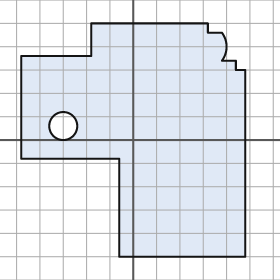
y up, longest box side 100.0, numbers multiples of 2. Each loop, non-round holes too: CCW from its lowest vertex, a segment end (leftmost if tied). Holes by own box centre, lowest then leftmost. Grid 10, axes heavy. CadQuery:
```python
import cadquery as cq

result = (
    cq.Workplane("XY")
    .moveTo(-6.0, -50.0)
    .lineTo(48.0, -50.0)
    .lineTo(48.0, 30.0)
    .lineTo(44.0, 30.0)
    .lineTo(44.0, 34.0)
    .lineTo(38.0, 34.0)
    .threePointArc((40.0, 40.0), (38.0, 46.0))
    .lineTo(32.0, 46.0)
    .lineTo(32.0, 50.0)
    .lineTo(-18.0, 50.0)
    .lineTo(-18.0, 36.0)
    .lineTo(-48.0, 36.0)
    .lineTo(-48.0, -8.0)
    .lineTo(-6.0, -8.0)
    .close()
    .moveTo(-30.0, 6.0)
    .circle(6.0)
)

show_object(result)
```